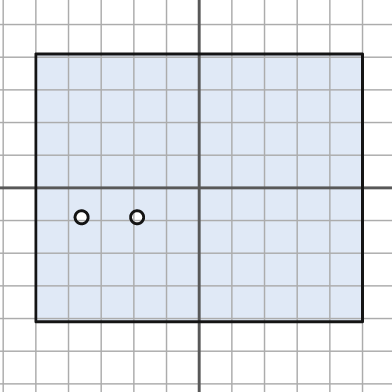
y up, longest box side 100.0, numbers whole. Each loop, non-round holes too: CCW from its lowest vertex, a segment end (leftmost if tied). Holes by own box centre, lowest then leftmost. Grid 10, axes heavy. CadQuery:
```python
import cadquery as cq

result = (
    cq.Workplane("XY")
    .moveTo(-50.0, -41.0)
    .lineTo(50.0, -41.0)
    .lineTo(50.0, 41.0)
    .lineTo(-50.0, 41.0)
    .close()
    .moveTo(-36.0, -9.0)
    .circle(2.0)
    .moveTo(-19.0, -9.0)
    .circle(2.0)
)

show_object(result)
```